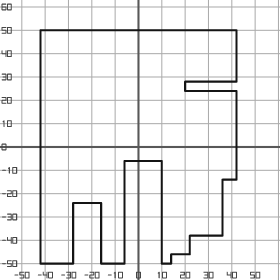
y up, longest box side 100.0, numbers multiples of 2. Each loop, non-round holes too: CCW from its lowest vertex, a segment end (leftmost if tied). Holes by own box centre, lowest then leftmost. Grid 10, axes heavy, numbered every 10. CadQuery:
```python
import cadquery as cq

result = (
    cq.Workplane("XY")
    .moveTo(-42.0, -50.0)
    .lineTo(-28.0, -50.0)
    .lineTo(-28.0, -24.0)
    .lineTo(-16.0, -24.0)
    .lineTo(-16.0, -50.0)
    .lineTo(-6.0, -50.0)
    .lineTo(-6.0, -6.0)
    .lineTo(10.0, -6.0)
    .lineTo(10.0, -50.0)
    .lineTo(14.0, -50.0)
    .lineTo(14.0, -46.0)
    .lineTo(22.0, -46.0)
    .lineTo(22.0, -38.0)
    .lineTo(36.0, -38.0)
    .lineTo(36.0, -14.0)
    .lineTo(42.0, -14.0)
    .lineTo(42.0, 24.0)
    .lineTo(20.0, 24.0)
    .lineTo(20.0, 28.0)
    .lineTo(42.0, 28.0)
    .lineTo(42.0, 50.0)
    .lineTo(-42.0, 50.0)
    .close()
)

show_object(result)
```